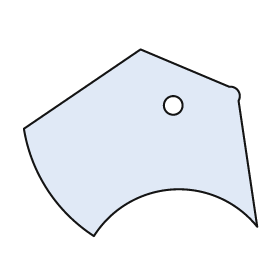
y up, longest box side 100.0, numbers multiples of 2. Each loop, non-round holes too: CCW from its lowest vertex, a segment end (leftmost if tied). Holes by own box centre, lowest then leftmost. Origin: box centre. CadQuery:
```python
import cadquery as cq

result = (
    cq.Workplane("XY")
    .moveTo(-20.0, -40.0)
    .threePointArc((14.0, -20.0), (50.0, -36.0))
    .lineTo(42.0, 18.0)
    .threePointArc((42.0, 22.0), (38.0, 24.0))
    .lineTo(0.0, 40.0)
    .lineTo(-50.0, 6.0)
    .threePointArc((-40.0, -20.0), (-20.0, -40.0))
    .close()
    .moveTo(14.0, 16.0)
    .circle(4.0)
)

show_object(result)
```